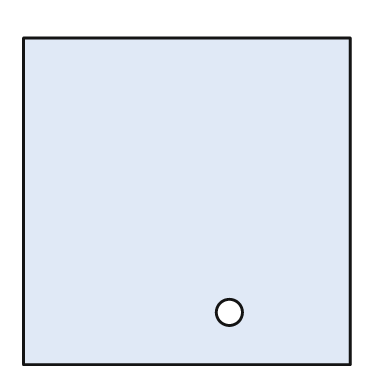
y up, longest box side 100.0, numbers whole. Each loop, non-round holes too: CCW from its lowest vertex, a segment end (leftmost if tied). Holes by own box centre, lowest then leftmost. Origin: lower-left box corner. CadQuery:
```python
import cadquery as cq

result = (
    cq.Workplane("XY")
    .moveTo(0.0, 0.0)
    .lineTo(100.0, 0.0)
    .lineTo(100.0, 100.0)
    .lineTo(0.0, 100.0)
    .close()
    .moveTo(63.0, 16.0)
    .circle(4.0)
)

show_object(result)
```